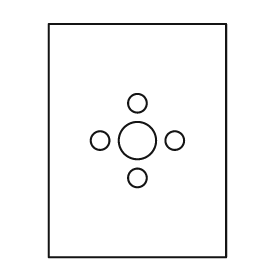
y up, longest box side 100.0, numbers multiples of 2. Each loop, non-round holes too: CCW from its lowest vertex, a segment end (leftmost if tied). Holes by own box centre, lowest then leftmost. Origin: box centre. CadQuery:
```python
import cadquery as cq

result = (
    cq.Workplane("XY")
    .moveTo(-38.0, -50.0)
    .lineTo(38.0, -50.0)
    .lineTo(38.0, 50.0)
    .lineTo(-38.0, 50.0)
    .close()
    .moveTo(0.0, -16.0)
    .circle(4.0)
    .moveTo(-16.0, 0.0)
    .circle(4.0)
    .moveTo(0.0, 0.0)
    .circle(8.0)
    .moveTo(16.0, 0.0)
    .circle(4.0)
    .moveTo(0.0, 16.0)
    .circle(4.0)
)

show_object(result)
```